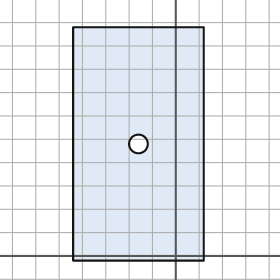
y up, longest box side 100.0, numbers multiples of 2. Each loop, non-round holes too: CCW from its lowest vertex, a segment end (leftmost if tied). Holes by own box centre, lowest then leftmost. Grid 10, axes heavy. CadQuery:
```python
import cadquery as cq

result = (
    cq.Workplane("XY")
    .moveTo(-44.0, -2.0)
    .lineTo(12.0, -2.0)
    .lineTo(12.0, 98.0)
    .lineTo(-44.0, 98.0)
    .close()
    .moveTo(-16.0, 48.0)
    .circle(4.0)
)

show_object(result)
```